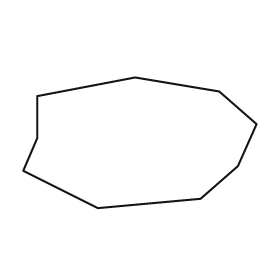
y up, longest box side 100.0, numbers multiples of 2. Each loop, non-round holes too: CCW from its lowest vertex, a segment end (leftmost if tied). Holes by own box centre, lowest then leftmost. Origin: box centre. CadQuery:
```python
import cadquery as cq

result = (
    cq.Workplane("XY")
    .moveTo(-18.0, -28.0)
    .lineTo(26.0, -24.0)
    .lineTo(42.0, -10.0)
    .lineTo(50.0, 8.0)
    .lineTo(34.0, 22.0)
    .lineTo(-2.0, 28.0)
    .lineTo(-44.0, 20.0)
    .lineTo(-44.0, 2.0)
    .lineTo(-50.0, -12.0)
    .close()
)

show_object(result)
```